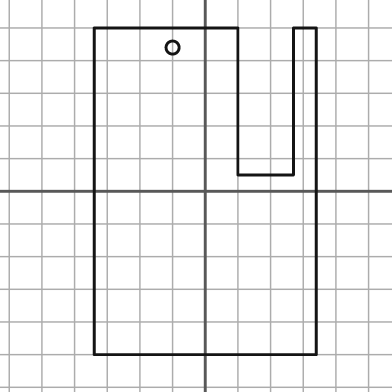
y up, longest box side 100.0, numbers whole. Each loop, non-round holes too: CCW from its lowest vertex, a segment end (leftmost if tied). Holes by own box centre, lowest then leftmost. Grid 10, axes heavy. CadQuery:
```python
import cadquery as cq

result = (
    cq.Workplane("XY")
    .moveTo(-34.0, -50.0)
    .lineTo(34.0, -50.0)
    .lineTo(34.0, 50.0)
    .lineTo(27.0, 50.0)
    .lineTo(27.0, 5.0)
    .lineTo(10.0, 5.0)
    .lineTo(10.0, 50.0)
    .lineTo(-34.0, 50.0)
    .close()
    .moveTo(-10.0, 44.0)
    .circle(2.0)
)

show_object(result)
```